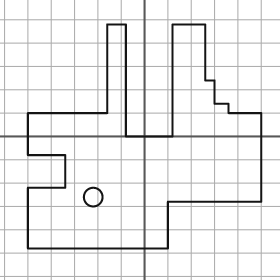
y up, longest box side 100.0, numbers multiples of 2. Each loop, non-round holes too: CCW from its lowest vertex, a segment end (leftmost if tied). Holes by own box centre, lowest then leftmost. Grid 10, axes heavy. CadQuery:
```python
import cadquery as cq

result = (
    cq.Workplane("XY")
    .moveTo(-50.0, -48.0)
    .lineTo(10.0, -48.0)
    .lineTo(10.0, -28.0)
    .lineTo(50.0, -28.0)
    .lineTo(50.0, 10.0)
    .lineTo(36.0, 10.0)
    .lineTo(36.0, 14.0)
    .lineTo(30.0, 14.0)
    .lineTo(30.0, 24.0)
    .lineTo(26.0, 24.0)
    .lineTo(26.0, 48.0)
    .lineTo(12.0, 48.0)
    .lineTo(12.0, 0.0)
    .lineTo(-8.0, 0.0)
    .lineTo(-8.0, 48.0)
    .lineTo(-16.0, 48.0)
    .lineTo(-16.0, 10.0)
    .lineTo(-50.0, 10.0)
    .lineTo(-50.0, -8.0)
    .lineTo(-34.0, -8.0)
    .lineTo(-34.0, -22.0)
    .lineTo(-50.0, -22.0)
    .close()
    .moveTo(-22.0, -26.0)
    .circle(4.0)
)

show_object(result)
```